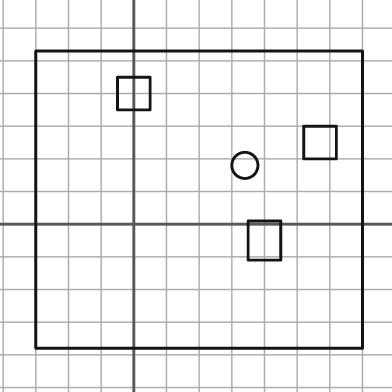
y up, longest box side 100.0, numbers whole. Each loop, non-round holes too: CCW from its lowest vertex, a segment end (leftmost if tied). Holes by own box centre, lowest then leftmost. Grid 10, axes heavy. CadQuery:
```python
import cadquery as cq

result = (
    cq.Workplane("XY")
    .moveTo(-30.0, -38.0)
    .lineTo(70.0, -38.0)
    .lineTo(70.0, 53.0)
    .lineTo(-30.0, 53.0)
    .close()
    .moveTo(35.0, -11.0)
    .lineTo(45.0, -11.0)
    .lineTo(45.0, 1.0)
    .lineTo(35.0, 1.0)
    .close()
    .moveTo(34.0, 18.0)
    .circle(4.0)
    .moveTo(52.0, 20.0)
    .lineTo(62.0, 20.0)
    .lineTo(62.0, 30.0)
    .lineTo(52.0, 30.0)
    .close()
    .moveTo(-5.0, 35.0)
    .lineTo(5.0, 35.0)
    .lineTo(5.0, 45.0)
    .lineTo(-5.0, 45.0)
    .close()
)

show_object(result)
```